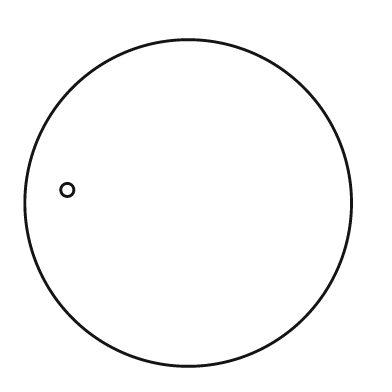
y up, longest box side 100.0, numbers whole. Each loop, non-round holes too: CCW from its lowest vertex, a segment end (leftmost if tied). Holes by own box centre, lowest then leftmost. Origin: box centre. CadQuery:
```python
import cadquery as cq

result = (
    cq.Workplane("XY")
    .moveTo(0.0, 0.0)
    .circle(50.0)
    .moveTo(-37.0, 4.0)
    .circle(2.0)
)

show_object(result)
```